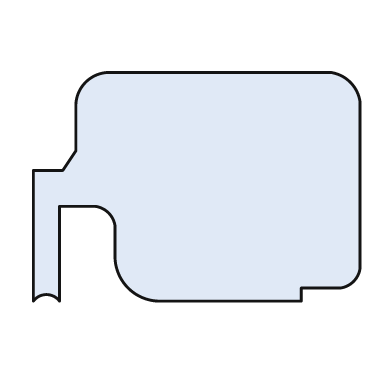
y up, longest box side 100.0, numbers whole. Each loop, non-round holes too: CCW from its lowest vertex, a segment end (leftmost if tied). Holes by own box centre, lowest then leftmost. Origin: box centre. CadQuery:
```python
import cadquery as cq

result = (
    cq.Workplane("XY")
    .moveTo(-50.0, -35.0)
    .threePointArc((-46.0, -33.0), (-42.0, -35.0))
    .lineTo(-42.0, -6.0)
    .lineTo(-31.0, -6.0)
    .threePointArc((-27.0, -8.0), (-25.0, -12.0))
    .lineTo(-25.0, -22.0)
    .threePointArc((-21.0, -31.0), (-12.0, -35.0))
    .lineTo(32.0, -35.0)
    .lineTo(32.0, -31.0)
    .lineTo(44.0, -31.0)
    .threePointArc((48.0, -29.0), (50.0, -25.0))
    .lineTo(50.0, 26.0)
    .threePointArc((47.0, 32.0), (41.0, 35.0))
    .lineTo(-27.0, 35.0)
    .threePointArc((-34.0, 32.0), (-37.0, 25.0))
    .lineTo(-37.0, 11.0)
    .lineTo(-41.0, 5.0)
    .lineTo(-50.0, 5.0)
    .close()
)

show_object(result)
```